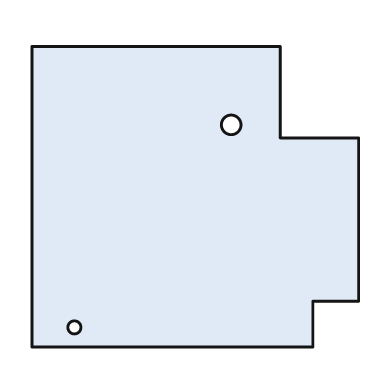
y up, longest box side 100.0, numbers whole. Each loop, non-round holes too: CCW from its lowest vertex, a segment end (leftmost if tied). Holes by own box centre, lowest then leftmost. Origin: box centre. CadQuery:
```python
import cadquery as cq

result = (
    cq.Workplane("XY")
    .moveTo(-50.0, -46.0)
    .lineTo(36.0, -46.0)
    .lineTo(36.0, -32.0)
    .lineTo(50.0, -32.0)
    .lineTo(50.0, 18.0)
    .lineTo(26.0, 18.0)
    .lineTo(26.0, 46.0)
    .lineTo(-50.0, 46.0)
    .close()
    .moveTo(-37.0, -40.0)
    .circle(2.0)
    .moveTo(11.0, 22.0)
    .circle(3.0)
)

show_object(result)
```